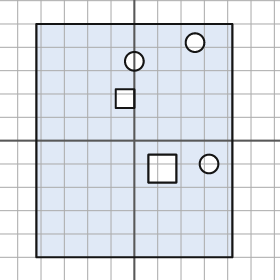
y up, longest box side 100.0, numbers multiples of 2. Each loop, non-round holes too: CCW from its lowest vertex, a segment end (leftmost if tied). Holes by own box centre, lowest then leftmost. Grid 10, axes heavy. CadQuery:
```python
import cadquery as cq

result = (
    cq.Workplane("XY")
    .moveTo(-42.0, -50.0)
    .lineTo(42.0, -50.0)
    .lineTo(42.0, 50.0)
    .lineTo(-42.0, 50.0)
    .close()
    .moveTo(6.0, -18.0)
    .lineTo(18.0, -18.0)
    .lineTo(18.0, -6.0)
    .lineTo(6.0, -6.0)
    .close()
    .moveTo(32.0, -10.0)
    .circle(4.0)
    .moveTo(-8.0, 14.0)
    .lineTo(0.0, 14.0)
    .lineTo(0.0, 22.0)
    .lineTo(-8.0, 22.0)
    .close()
    .moveTo(0.0, 34.0)
    .circle(4.0)
    .moveTo(26.0, 42.0)
    .circle(4.0)
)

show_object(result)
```